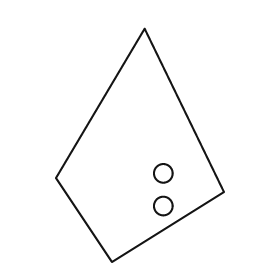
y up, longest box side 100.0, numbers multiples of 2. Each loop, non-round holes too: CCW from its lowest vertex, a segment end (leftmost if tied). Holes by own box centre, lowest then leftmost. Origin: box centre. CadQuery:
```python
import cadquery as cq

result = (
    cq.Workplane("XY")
    .moveTo(-12.0, -50.0)
    .lineTo(36.0, -20.0)
    .lineTo(2.0, 50.0)
    .lineTo(-36.0, -14.0)
    .close()
    .moveTo(10.0, -26.0)
    .circle(4.0)
    .moveTo(10.0, -12.0)
    .circle(4.0)
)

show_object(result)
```